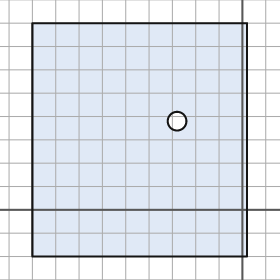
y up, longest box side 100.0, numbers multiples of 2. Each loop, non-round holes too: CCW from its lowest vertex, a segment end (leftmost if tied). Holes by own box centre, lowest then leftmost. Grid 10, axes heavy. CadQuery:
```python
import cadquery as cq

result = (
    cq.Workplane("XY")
    .moveTo(-90.0, -20.0)
    .lineTo(2.0, -20.0)
    .lineTo(2.0, 80.0)
    .lineTo(-90.0, 80.0)
    .close()
    .moveTo(-28.0, 38.0)
    .circle(4.0)
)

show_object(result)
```